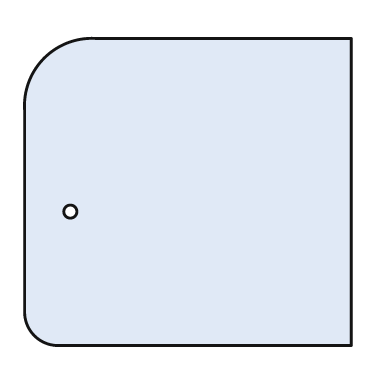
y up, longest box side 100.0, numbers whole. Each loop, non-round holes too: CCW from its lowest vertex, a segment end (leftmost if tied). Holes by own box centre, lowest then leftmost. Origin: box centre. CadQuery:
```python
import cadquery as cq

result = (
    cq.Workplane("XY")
    .moveTo(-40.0, -47.0)
    .lineTo(50.0, -47.0)
    .lineTo(50.0, 47.0)
    .lineTo(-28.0, 47.0)
    .threePointArc((-44.0, 41.0), (-50.0, 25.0))
    .lineTo(-50.0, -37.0)
    .threePointArc((-47.0, -44.0), (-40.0, -47.0))
    .close()
    .moveTo(-36.0, -6.0)
    .circle(2.0)
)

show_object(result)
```